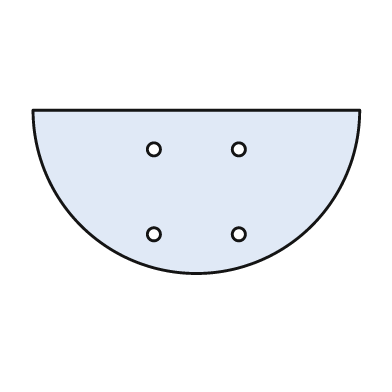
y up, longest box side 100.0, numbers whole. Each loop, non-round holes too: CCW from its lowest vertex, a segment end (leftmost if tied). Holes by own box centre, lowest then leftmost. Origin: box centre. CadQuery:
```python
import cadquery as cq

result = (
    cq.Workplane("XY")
    .moveTo(-50.0, 25.0)
    .threePointArc((0.0, -25.0), (50.0, 25.0))
    .close()
    .moveTo(-13.0, -13.0)
    .circle(2.0)
    .moveTo(13.0, -13.0)
    .circle(2.0)
    .moveTo(-13.0, 13.0)
    .circle(2.0)
    .moveTo(13.0, 13.0)
    .circle(2.0)
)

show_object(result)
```